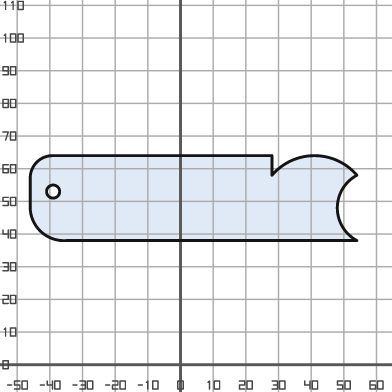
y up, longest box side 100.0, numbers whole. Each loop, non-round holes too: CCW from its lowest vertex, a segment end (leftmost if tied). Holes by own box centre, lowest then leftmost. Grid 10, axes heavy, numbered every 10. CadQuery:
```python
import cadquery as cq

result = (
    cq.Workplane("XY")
    .moveTo(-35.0, 38.0)
    .lineTo(54.0, 38.0)
    .threePointArc((48.0, 48.0), (54.0, 58.0))
    .threePointArc((41.0, 64.0), (28.0, 58.0))
    .lineTo(28.0, 64.0)
    .lineTo(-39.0, 64.0)
    .threePointArc((-44.0, 62.0), (-46.0, 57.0))
    .lineTo(-46.0, 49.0)
    .threePointArc((-43.0, 41.0), (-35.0, 38.0))
    .close()
    .moveTo(-39.0, 53.0)
    .circle(2.0)
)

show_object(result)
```